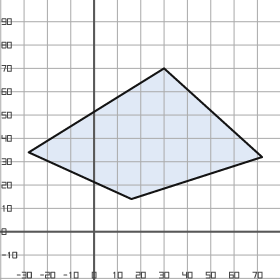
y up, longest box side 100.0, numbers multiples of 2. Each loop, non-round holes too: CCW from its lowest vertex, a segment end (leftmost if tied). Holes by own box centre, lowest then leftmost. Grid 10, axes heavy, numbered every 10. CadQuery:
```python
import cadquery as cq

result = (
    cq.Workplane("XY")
    .moveTo(16.0, 14.0)
    .lineTo(72.0, 32.0)
    .lineTo(30.0, 70.0)
    .lineTo(-28.0, 34.0)
    .close()
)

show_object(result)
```